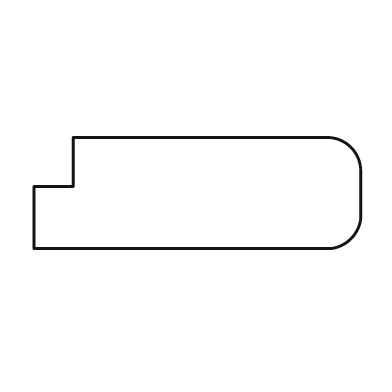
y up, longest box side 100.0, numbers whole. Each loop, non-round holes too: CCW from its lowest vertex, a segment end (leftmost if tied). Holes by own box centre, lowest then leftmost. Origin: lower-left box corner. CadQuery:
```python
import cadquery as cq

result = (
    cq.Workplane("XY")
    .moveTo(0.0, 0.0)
    .lineTo(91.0, 0.0)
    .threePointArc((97.0, 3.0), (100.0, 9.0))
    .lineTo(100.0, 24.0)
    .threePointArc((97.0, 31.0), (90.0, 34.0))
    .lineTo(12.0, 34.0)
    .lineTo(12.0, 19.0)
    .lineTo(0.0, 19.0)
    .close()
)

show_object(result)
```